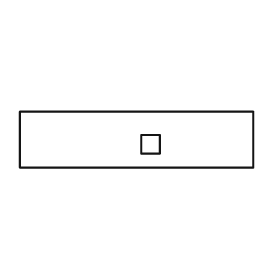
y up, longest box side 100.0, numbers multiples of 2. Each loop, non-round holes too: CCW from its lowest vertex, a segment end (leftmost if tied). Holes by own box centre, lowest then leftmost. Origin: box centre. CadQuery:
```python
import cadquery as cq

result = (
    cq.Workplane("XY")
    .moveTo(-50.0, -12.0)
    .lineTo(50.0, -12.0)
    .lineTo(50.0, 12.0)
    .lineTo(-50.0, 12.0)
    .close()
    .moveTo(2.0, -6.0)
    .lineTo(10.0, -6.0)
    .lineTo(10.0, 2.0)
    .lineTo(2.0, 2.0)
    .close()
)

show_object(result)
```